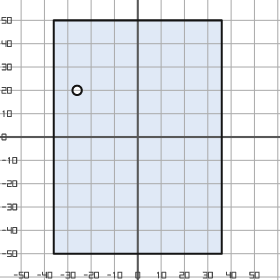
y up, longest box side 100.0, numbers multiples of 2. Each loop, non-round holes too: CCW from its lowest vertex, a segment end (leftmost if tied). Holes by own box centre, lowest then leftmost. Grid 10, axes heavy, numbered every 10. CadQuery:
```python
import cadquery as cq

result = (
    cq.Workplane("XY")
    .moveTo(-36.0, -50.0)
    .lineTo(36.0, -50.0)
    .lineTo(36.0, 50.0)
    .lineTo(-36.0, 50.0)
    .close()
    .moveTo(-26.0, 20.0)
    .circle(2.0)
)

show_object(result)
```